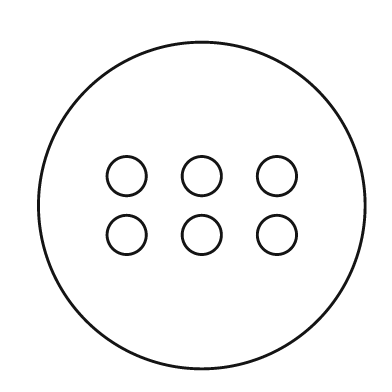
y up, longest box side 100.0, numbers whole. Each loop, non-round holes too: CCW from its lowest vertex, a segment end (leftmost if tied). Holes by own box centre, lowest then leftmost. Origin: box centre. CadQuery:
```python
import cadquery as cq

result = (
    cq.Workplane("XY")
    .moveTo(0.0, 0.0)
    .circle(50.0)
    .moveTo(-23.0, -9.0)
    .circle(6.0)
    .moveTo(0.0, -9.0)
    .circle(6.0)
    .moveTo(23.0, -9.0)
    .circle(6.0)
    .moveTo(-23.0, 9.0)
    .circle(6.0)
    .moveTo(0.0, 9.0)
    .circle(6.0)
    .moveTo(23.0, 9.0)
    .circle(6.0)
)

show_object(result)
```